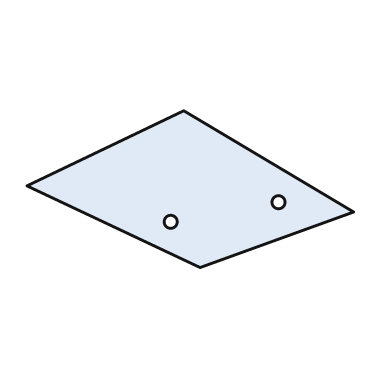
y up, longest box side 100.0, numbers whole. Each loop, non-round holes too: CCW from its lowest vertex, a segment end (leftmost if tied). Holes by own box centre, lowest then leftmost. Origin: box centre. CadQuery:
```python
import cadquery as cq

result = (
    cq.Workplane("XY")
    .moveTo(3.0, -24.0)
    .lineTo(50.0, -7.0)
    .lineTo(-2.0, 24.0)
    .lineTo(-50.0, 1.0)
    .close()
    .moveTo(-6.0, -10.0)
    .circle(2.0)
    .moveTo(27.0, -4.0)
    .circle(2.0)
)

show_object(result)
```